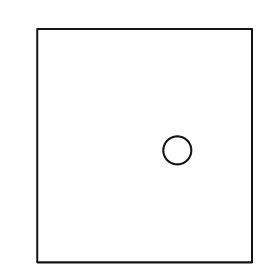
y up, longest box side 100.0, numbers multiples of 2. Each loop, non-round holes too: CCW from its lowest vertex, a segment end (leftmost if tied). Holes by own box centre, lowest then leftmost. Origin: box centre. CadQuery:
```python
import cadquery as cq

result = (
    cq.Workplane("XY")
    .moveTo(-46.0, -50.0)
    .lineTo(46.0, -50.0)
    .lineTo(46.0, 50.0)
    .lineTo(-46.0, 50.0)
    .close()
    .moveTo(14.0, -2.0)
    .circle(6.0)
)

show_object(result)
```